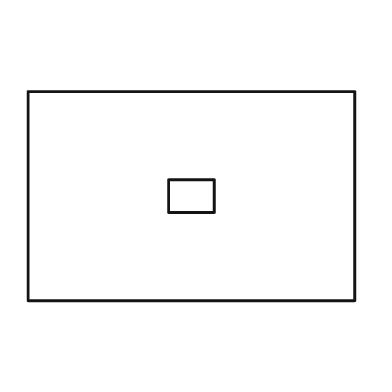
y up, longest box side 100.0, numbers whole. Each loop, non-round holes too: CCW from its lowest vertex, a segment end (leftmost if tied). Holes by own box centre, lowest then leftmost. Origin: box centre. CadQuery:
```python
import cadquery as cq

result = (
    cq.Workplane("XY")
    .moveTo(-50.0, -32.0)
    .lineTo(50.0, -32.0)
    .lineTo(50.0, 32.0)
    .lineTo(-50.0, 32.0)
    .close()
    .moveTo(-7.0, -5.0)
    .lineTo(7.0, -5.0)
    .lineTo(7.0, 5.0)
    .lineTo(-7.0, 5.0)
    .close()
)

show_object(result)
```